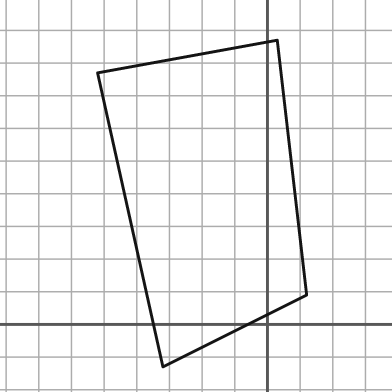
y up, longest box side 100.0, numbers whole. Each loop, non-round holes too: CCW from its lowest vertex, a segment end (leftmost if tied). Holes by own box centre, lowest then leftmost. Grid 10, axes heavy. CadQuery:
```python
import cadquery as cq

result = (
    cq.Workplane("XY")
    .moveTo(-32.0, -13.0)
    .lineTo(12.0, 9.0)
    .lineTo(3.0, 87.0)
    .lineTo(-52.0, 77.0)
    .close()
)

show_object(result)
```